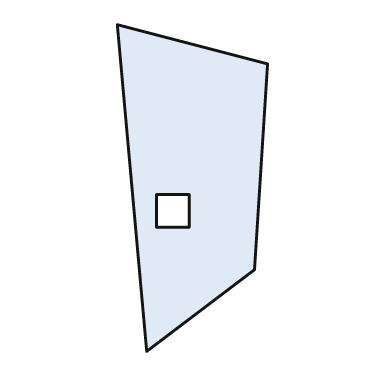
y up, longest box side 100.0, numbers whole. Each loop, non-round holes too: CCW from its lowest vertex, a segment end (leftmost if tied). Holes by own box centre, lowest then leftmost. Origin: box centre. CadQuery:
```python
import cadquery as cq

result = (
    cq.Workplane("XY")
    .moveTo(-14.0, -50.0)
    .lineTo(19.0, -25.0)
    .lineTo(23.0, 38.0)
    .lineTo(-23.0, 50.0)
    .close()
    .moveTo(-11.0, -12.0)
    .lineTo(-1.0, -12.0)
    .lineTo(-1.0, -2.0)
    .lineTo(-11.0, -2.0)
    .close()
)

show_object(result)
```